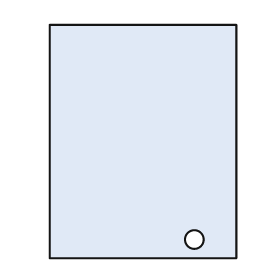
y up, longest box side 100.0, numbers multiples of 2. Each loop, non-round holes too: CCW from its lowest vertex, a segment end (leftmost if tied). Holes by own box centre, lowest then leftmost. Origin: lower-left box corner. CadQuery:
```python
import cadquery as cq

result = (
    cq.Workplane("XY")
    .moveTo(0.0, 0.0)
    .lineTo(80.0, 0.0)
    .lineTo(80.0, 100.0)
    .lineTo(0.0, 100.0)
    .close()
    .moveTo(62.0, 8.0)
    .circle(4.0)
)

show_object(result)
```